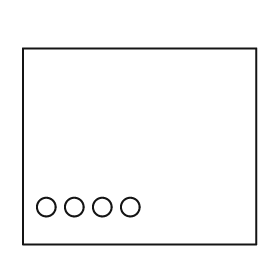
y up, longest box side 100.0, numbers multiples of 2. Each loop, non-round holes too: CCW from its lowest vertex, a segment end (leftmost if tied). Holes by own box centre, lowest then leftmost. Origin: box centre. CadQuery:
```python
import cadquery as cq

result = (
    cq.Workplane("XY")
    .moveTo(-50.0, -42.0)
    .lineTo(50.0, -42.0)
    .lineTo(50.0, 42.0)
    .lineTo(-50.0, 42.0)
    .close()
    .moveTo(-40.0, -26.0)
    .circle(4.0)
    .moveTo(-28.0, -26.0)
    .circle(4.0)
    .moveTo(-16.0, -26.0)
    .circle(4.0)
    .moveTo(-4.0, -26.0)
    .circle(4.0)
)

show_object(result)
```